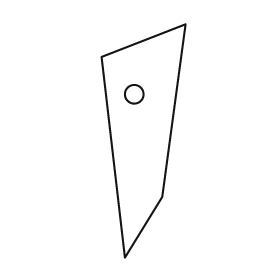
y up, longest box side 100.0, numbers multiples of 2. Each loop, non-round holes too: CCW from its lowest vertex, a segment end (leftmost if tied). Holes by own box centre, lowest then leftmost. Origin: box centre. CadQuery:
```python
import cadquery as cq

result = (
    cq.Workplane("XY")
    .moveTo(-8.0, -50.0)
    .lineTo(8.0, -24.0)
    .lineTo(18.0, 50.0)
    .lineTo(-18.0, 36.0)
    .close()
    .moveTo(-4.0, 20.0)
    .circle(4.0)
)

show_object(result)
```